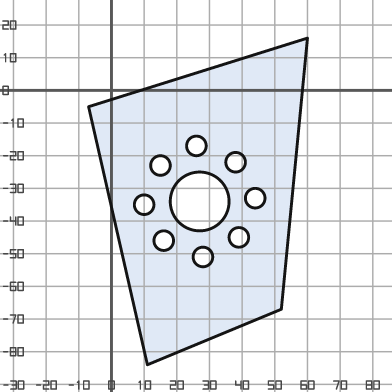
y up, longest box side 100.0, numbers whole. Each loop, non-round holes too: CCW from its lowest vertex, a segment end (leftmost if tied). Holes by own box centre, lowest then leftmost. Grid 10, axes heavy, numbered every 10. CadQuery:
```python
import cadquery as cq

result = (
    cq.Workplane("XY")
    .moveTo(11.0, -84.0)
    .lineTo(52.0, -67.0)
    .lineTo(60.0, 16.0)
    .lineTo(-7.0, -5.0)
    .close()
    .moveTo(28.0, -51.0)
    .circle(3.0)
    .moveTo(16.0, -46.0)
    .circle(3.0)
    .moveTo(39.0, -45.0)
    .circle(3.0)
    .moveTo(10.0, -35.0)
    .circle(3.0)
    .moveTo(27.0, -34.0)
    .circle(9.0)
    .moveTo(44.0, -33.0)
    .circle(3.0)
    .moveTo(15.0, -23.0)
    .circle(3.0)
    .moveTo(38.0, -22.0)
    .circle(3.0)
    .moveTo(26.0, -17.0)
    .circle(3.0)
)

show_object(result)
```